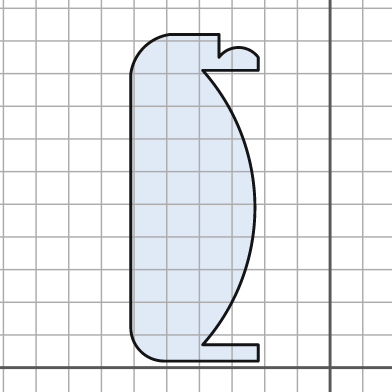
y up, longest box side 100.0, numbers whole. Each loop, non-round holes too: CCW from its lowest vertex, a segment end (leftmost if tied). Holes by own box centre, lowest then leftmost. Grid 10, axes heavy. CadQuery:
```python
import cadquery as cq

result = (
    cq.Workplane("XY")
    .moveTo(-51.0, 2.0)
    .lineTo(-22.0, 2.0)
    .lineTo(-22.0, 7.0)
    .lineTo(-39.0, 7.0)
    .threePointArc((-23.0, 49.0), (-39.0, 91.0))
    .lineTo(-22.0, 91.0)
    .lineTo(-22.0, 95.0)
    .threePointArc((-28.0, 98.0), (-34.0, 95.0))
    .lineTo(-34.0, 102.0)
    .lineTo(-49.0, 102.0)
    .threePointArc((-57.0, 98.0), (-61.0, 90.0))
    .lineTo(-61.0, 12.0)
    .threePointArc((-58.0, 5.0), (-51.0, 2.0))
    .close()
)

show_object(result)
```